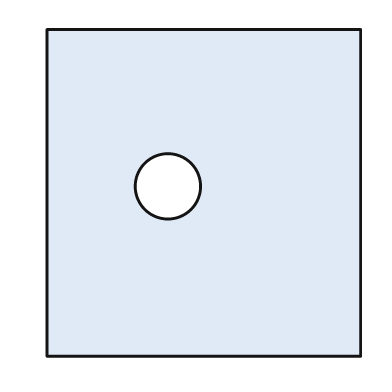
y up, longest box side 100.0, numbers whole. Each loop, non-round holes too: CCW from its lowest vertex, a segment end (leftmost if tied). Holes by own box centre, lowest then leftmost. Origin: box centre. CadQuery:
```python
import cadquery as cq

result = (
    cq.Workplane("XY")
    .moveTo(-48.0, -50.0)
    .lineTo(48.0, -50.0)
    .lineTo(48.0, 50.0)
    .lineTo(-48.0, 50.0)
    .close()
    .moveTo(-11.0, 2.0)
    .circle(10.0)
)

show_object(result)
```